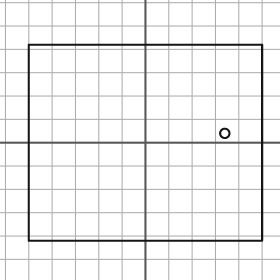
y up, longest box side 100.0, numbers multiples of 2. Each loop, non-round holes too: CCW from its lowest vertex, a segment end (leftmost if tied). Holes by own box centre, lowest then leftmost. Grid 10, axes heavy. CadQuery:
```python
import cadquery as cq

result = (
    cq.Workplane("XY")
    .moveTo(-50.0, -42.0)
    .lineTo(50.0, -42.0)
    .lineTo(50.0, 42.0)
    .lineTo(-50.0, 42.0)
    .close()
    .moveTo(34.0, 4.0)
    .circle(2.0)
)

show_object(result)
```